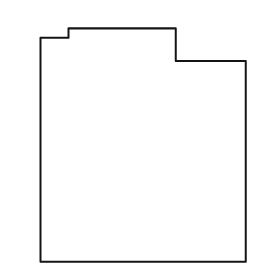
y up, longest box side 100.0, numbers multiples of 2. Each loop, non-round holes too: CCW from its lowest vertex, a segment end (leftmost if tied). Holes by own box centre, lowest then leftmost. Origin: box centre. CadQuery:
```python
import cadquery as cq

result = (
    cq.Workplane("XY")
    .moveTo(-44.0, -50.0)
    .lineTo(44.0, -50.0)
    .lineTo(44.0, 36.0)
    .lineTo(14.0, 36.0)
    .lineTo(14.0, 50.0)
    .lineTo(-32.0, 50.0)
    .lineTo(-32.0, 46.0)
    .lineTo(-44.0, 46.0)
    .close()
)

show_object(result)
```